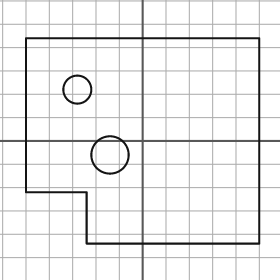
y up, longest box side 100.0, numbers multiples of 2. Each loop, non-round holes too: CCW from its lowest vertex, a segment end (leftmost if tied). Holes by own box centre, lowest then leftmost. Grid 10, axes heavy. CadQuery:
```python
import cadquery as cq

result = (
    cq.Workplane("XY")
    .moveTo(-24.0, -44.0)
    .lineTo(50.0, -44.0)
    .lineTo(50.0, 44.0)
    .lineTo(-50.0, 44.0)
    .lineTo(-50.0, -22.0)
    .lineTo(-24.0, -22.0)
    .close()
    .moveTo(-14.0, -6.0)
    .circle(8.0)
    .moveTo(-28.0, 22.0)
    .circle(6.0)
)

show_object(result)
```